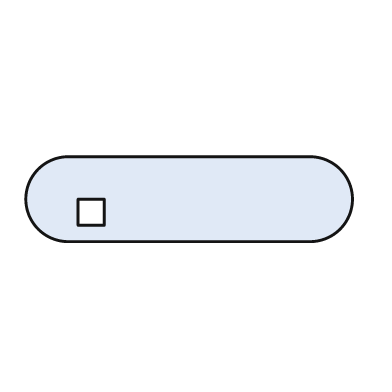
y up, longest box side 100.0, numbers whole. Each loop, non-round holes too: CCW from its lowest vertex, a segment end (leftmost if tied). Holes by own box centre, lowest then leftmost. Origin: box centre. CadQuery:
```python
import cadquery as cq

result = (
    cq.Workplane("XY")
    .moveTo(-37.0, -13.0)
    .lineTo(37.0, -13.0)
    .threePointArc((50.0, 0.0), (37.0, 13.0))
    .lineTo(-37.0, 13.0)
    .threePointArc((-50.0, 0.0), (-37.0, -13.0))
    .close()
    .moveTo(-34.0, -8.0)
    .lineTo(-26.0, -8.0)
    .lineTo(-26.0, 0.0)
    .lineTo(-34.0, 0.0)
    .close()
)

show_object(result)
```